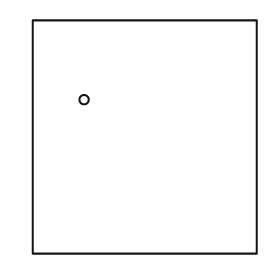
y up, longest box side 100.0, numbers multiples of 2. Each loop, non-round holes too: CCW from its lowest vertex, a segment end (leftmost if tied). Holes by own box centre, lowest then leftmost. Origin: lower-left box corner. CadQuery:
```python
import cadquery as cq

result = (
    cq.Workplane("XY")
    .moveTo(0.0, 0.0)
    .lineTo(96.0, 0.0)
    .lineTo(96.0, 100.0)
    .lineTo(0.0, 100.0)
    .close()
    .moveTo(22.0, 66.0)
    .circle(2.0)
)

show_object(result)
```